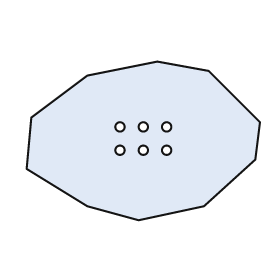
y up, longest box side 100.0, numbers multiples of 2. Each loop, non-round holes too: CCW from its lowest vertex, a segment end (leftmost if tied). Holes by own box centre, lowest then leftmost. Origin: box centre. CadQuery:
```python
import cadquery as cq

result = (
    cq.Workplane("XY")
    .moveTo(-2.0, -34.0)
    .lineTo(26.0, -28.0)
    .lineTo(48.0, -8.0)
    .lineTo(50.0, 8.0)
    .lineTo(28.0, 30.0)
    .lineTo(6.0, 34.0)
    .lineTo(-24.0, 28.0)
    .lineTo(-48.0, 10.0)
    .lineTo(-50.0, -12.0)
    .lineTo(-24.0, -28.0)
    .close()
    .moveTo(-10.0, -4.0)
    .circle(2.0)
    .moveTo(0.0, -4.0)
    .circle(2.0)
    .moveTo(10.0, -4.0)
    .circle(2.0)
    .moveTo(-10.0, 6.0)
    .circle(2.0)
    .moveTo(0.0, 6.0)
    .circle(2.0)
    .moveTo(10.0, 6.0)
    .circle(2.0)
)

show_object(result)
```